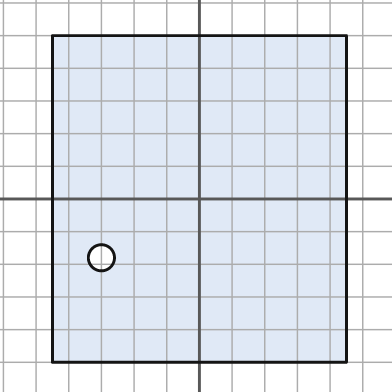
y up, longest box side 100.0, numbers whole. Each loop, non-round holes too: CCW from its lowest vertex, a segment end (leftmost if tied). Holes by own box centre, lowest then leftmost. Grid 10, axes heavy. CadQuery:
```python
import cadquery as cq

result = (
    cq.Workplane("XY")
    .moveTo(-45.0, -50.0)
    .lineTo(45.0, -50.0)
    .lineTo(45.0, 50.0)
    .lineTo(-45.0, 50.0)
    .close()
    .moveTo(-30.0, -18.0)
    .circle(4.0)
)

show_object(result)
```